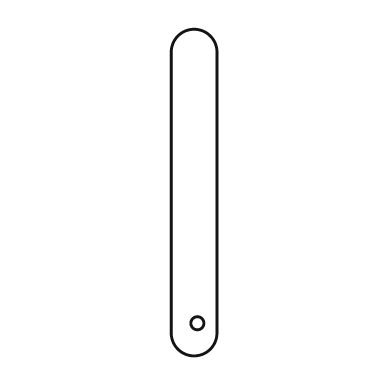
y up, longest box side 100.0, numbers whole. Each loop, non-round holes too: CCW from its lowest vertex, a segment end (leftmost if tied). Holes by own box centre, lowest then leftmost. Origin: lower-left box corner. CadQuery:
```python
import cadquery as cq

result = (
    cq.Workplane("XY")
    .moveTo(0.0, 7.0)
    .threePointArc((7.0, 0.0), (14.0, 7.0))
    .lineTo(14.0, 93.0)
    .threePointArc((7.0, 100.0), (0.0, 93.0))
    .close()
    .moveTo(8.0, 10.0)
    .circle(2.0)
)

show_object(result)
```